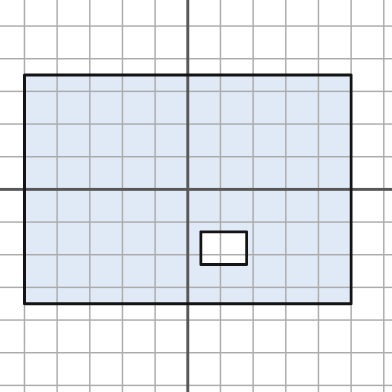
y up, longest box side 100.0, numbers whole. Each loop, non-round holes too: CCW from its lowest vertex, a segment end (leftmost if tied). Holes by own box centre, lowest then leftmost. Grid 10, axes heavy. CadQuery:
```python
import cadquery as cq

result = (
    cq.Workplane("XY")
    .moveTo(-50.0, -35.0)
    .lineTo(50.0, -35.0)
    .lineTo(50.0, 35.0)
    .lineTo(-50.0, 35.0)
    .close()
    .moveTo(4.0, -23.0)
    .lineTo(18.0, -23.0)
    .lineTo(18.0, -13.0)
    .lineTo(4.0, -13.0)
    .close()
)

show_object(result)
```